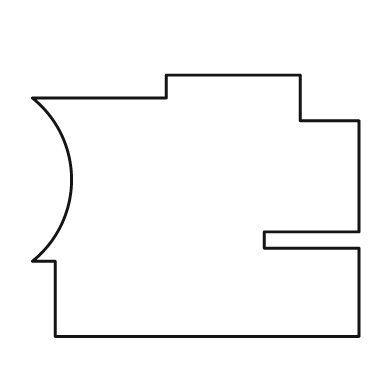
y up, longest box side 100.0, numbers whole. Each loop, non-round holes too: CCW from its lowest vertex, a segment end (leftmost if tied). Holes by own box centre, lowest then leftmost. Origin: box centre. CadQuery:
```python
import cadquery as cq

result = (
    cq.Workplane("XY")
    .moveTo(-43.0, -40.0)
    .lineTo(50.0, -40.0)
    .lineTo(50.0, -13.0)
    .lineTo(21.0, -13.0)
    .lineTo(21.0, -8.0)
    .lineTo(50.0, -8.0)
    .lineTo(50.0, 26.0)
    .lineTo(32.0, 26.0)
    .lineTo(32.0, 40.0)
    .lineTo(-9.0, 40.0)
    .lineTo(-9.0, 33.0)
    .lineTo(-50.0, 33.0)
    .threePointArc((-38.0, 8.0), (-50.0, -17.0))
    .lineTo(-43.0, -17.0)
    .close()
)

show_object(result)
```